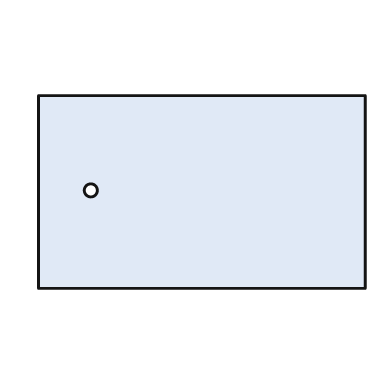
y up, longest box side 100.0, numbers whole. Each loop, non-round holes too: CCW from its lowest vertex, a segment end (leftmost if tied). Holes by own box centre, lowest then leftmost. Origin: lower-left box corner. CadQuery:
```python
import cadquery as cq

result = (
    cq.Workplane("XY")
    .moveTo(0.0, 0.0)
    .lineTo(100.0, 0.0)
    .lineTo(100.0, 59.0)
    .lineTo(0.0, 59.0)
    .close()
    .moveTo(16.0, 30.0)
    .circle(2.0)
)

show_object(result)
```